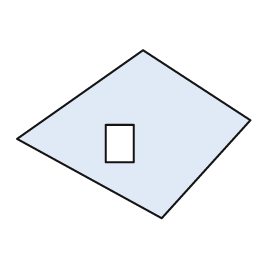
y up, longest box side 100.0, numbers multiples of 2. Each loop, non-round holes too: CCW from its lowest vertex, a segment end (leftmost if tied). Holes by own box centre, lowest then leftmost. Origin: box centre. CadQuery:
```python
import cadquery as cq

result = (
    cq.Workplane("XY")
    .moveTo(12.0, -36.0)
    .lineTo(50.0, 6.0)
    .lineTo(4.0, 36.0)
    .lineTo(-50.0, -2.0)
    .close()
    .moveTo(-12.0, -12.0)
    .lineTo(0.0, -12.0)
    .lineTo(0.0, 4.0)
    .lineTo(-12.0, 4.0)
    .close()
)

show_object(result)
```